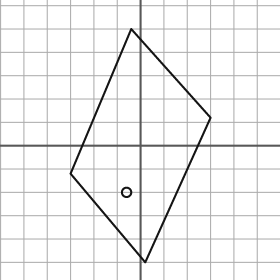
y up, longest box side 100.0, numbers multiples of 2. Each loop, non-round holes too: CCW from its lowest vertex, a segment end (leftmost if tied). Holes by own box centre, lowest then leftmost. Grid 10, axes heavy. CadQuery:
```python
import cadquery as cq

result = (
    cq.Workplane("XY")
    .moveTo(2.0, -50.0)
    .lineTo(30.0, 12.0)
    .lineTo(-4.0, 50.0)
    .lineTo(-30.0, -12.0)
    .close()
    .moveTo(-6.0, -20.0)
    .circle(2.0)
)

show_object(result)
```